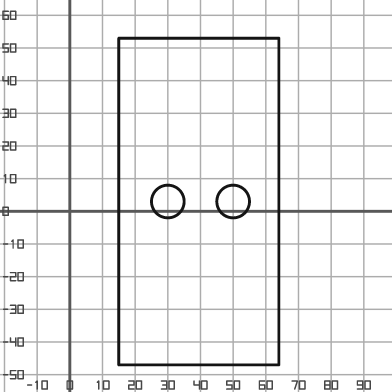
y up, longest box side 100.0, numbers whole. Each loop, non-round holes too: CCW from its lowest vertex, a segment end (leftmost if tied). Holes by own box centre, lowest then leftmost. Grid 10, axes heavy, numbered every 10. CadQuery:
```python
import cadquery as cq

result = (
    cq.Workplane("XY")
    .moveTo(15.0, -47.0)
    .lineTo(64.0, -47.0)
    .lineTo(64.0, 53.0)
    .lineTo(15.0, 53.0)
    .close()
    .moveTo(30.0, 3.0)
    .circle(5.0)
    .moveTo(50.0, 3.0)
    .circle(5.0)
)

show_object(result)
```